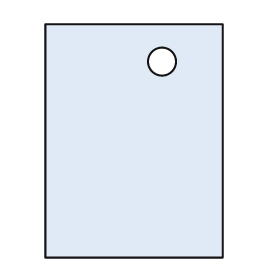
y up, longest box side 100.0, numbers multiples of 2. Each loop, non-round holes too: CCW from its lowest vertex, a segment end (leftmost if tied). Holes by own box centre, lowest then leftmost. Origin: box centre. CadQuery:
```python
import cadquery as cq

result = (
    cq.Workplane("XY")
    .moveTo(-38.0, -50.0)
    .lineTo(38.0, -50.0)
    .lineTo(38.0, 50.0)
    .lineTo(-38.0, 50.0)
    .close()
    .moveTo(12.0, 34.0)
    .circle(6.0)
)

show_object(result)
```